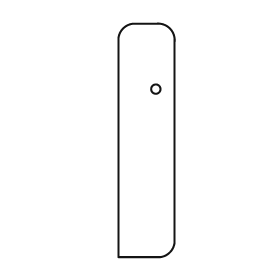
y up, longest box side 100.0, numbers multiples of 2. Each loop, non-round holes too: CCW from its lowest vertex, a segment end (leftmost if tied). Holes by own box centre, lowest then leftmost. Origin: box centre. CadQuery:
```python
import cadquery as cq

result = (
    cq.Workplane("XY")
    .moveTo(-12.0, -50.0)
    .lineTo(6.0, -50.0)
    .threePointArc((10.0, -48.0), (12.0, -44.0))
    .lineTo(12.0, 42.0)
    .threePointArc((10.0, 48.0), (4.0, 50.0))
    .lineTo(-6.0, 50.0)
    .threePointArc((-10.0, 48.0), (-12.0, 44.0))
    .close()
    .moveTo(4.0, 22.0)
    .circle(2.0)
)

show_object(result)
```